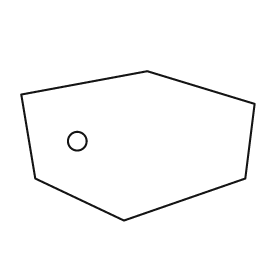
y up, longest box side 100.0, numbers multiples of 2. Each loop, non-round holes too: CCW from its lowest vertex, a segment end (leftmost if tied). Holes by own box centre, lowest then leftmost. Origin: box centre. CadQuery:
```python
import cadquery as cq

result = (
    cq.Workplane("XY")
    .moveTo(-6.0, -32.0)
    .lineTo(46.0, -14.0)
    .lineTo(50.0, 18.0)
    .lineTo(4.0, 32.0)
    .lineTo(-50.0, 22.0)
    .lineTo(-44.0, -14.0)
    .close()
    .moveTo(-26.0, 2.0)
    .circle(4.0)
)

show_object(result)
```